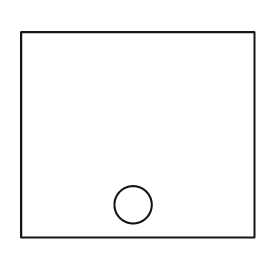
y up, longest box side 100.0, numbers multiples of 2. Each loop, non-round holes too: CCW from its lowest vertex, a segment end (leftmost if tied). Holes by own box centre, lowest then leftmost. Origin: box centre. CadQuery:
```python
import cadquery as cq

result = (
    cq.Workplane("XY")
    .moveTo(-50.0, -44.0)
    .lineTo(50.0, -44.0)
    .lineTo(50.0, 44.0)
    .lineTo(-50.0, 44.0)
    .close()
    .moveTo(-2.0, -30.0)
    .circle(8.0)
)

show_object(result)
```